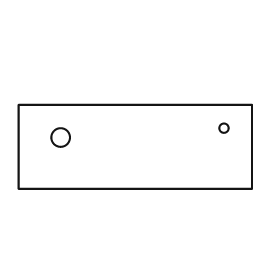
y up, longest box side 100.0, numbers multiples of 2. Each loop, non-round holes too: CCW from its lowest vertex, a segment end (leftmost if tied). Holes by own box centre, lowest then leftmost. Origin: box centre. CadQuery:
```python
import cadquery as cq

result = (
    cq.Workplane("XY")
    .moveTo(-50.0, -18.0)
    .lineTo(50.0, -18.0)
    .lineTo(50.0, 18.0)
    .lineTo(-50.0, 18.0)
    .close()
    .moveTo(-32.0, 4.0)
    .circle(4.0)
    .moveTo(38.0, 8.0)
    .circle(2.0)
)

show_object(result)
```